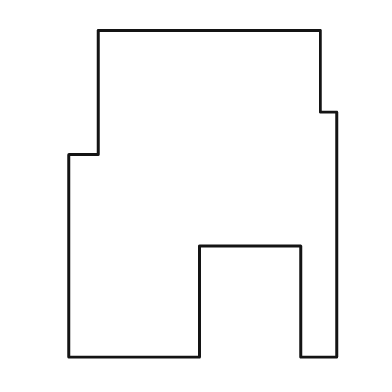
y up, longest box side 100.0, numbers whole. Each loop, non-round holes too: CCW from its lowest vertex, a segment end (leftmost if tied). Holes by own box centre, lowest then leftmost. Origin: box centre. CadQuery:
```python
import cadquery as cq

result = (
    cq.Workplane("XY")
    .moveTo(-41.0, -50.0)
    .lineTo(-1.0, -50.0)
    .lineTo(-1.0, -16.0)
    .lineTo(30.0, -16.0)
    .lineTo(30.0, -50.0)
    .lineTo(41.0, -50.0)
    .lineTo(41.0, 25.0)
    .lineTo(36.0, 25.0)
    .lineTo(36.0, 50.0)
    .lineTo(-32.0, 50.0)
    .lineTo(-32.0, 12.0)
    .lineTo(-41.0, 12.0)
    .close()
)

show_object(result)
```